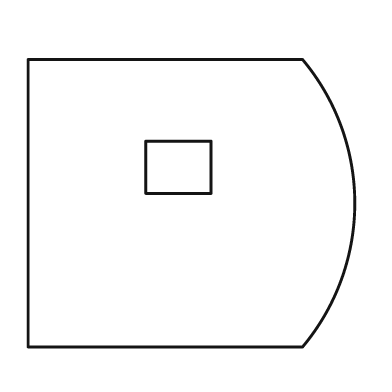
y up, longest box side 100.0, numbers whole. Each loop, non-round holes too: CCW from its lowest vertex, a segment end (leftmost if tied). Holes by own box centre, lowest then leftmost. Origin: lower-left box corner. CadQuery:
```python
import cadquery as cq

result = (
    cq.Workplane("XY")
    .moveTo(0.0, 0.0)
    .lineTo(84.0, 0.0)
    .threePointArc((100.0, 44.0), (84.0, 88.0))
    .lineTo(0.0, 88.0)
    .close()
    .moveTo(36.0, 47.0)
    .lineTo(56.0, 47.0)
    .lineTo(56.0, 63.0)
    .lineTo(36.0, 63.0)
    .close()
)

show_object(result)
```